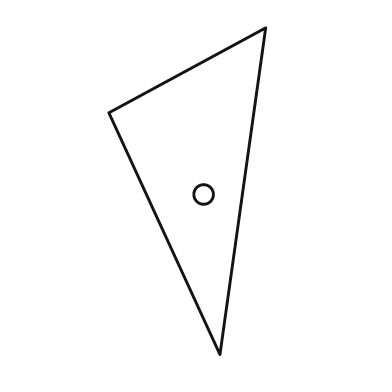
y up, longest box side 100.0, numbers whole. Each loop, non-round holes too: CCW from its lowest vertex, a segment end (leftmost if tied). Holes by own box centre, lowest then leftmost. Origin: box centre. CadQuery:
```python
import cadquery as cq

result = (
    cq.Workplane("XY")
    .moveTo(10.0, -50.0)
    .lineTo(24.0, 50.0)
    .lineTo(-24.0, 24.0)
    .close()
    .moveTo(5.0, -1.0)
    .circle(3.0)
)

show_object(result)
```